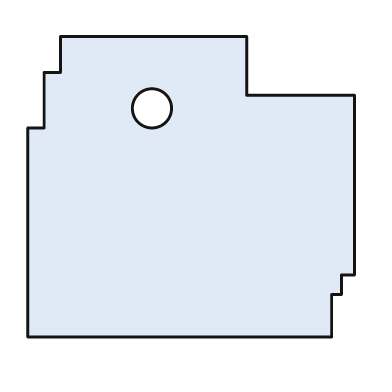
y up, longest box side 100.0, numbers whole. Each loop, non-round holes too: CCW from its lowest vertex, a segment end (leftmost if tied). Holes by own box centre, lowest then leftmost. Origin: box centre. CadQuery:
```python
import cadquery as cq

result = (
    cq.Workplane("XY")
    .moveTo(-50.0, -46.0)
    .lineTo(43.0, -46.0)
    .lineTo(43.0, -33.0)
    .lineTo(46.0, -33.0)
    .lineTo(46.0, -27.0)
    .lineTo(50.0, -27.0)
    .lineTo(50.0, 28.0)
    .lineTo(17.0, 28.0)
    .lineTo(17.0, 46.0)
    .lineTo(-40.0, 46.0)
    .lineTo(-40.0, 35.0)
    .lineTo(-45.0, 35.0)
    .lineTo(-45.0, 18.0)
    .lineTo(-50.0, 18.0)
    .close()
    .moveTo(-12.0, 24.0)
    .circle(6.0)
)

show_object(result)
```